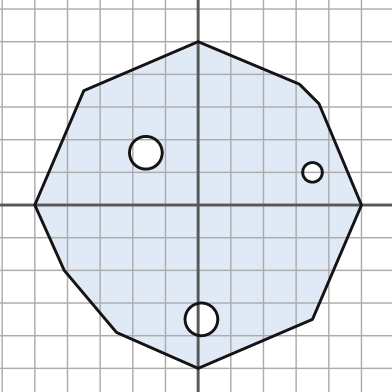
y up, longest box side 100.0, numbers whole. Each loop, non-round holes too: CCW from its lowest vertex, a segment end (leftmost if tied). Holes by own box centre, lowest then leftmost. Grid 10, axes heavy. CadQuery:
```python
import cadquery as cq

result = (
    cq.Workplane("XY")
    .moveTo(0.0, -50.0)
    .lineTo(35.0, -35.0)
    .lineTo(50.0, 0.0)
    .lineTo(37.0, 31.0)
    .lineTo(31.0, 37.0)
    .lineTo(0.0, 50.0)
    .lineTo(-35.0, 35.0)
    .lineTo(-50.0, 0.0)
    .lineTo(-41.0, -20.0)
    .lineTo(-25.0, -39.0)
    .close()
    .moveTo(1.0, -35.0)
    .circle(5.0)
    .moveTo(35.0, 10.0)
    .circle(3.0)
    .moveTo(-16.0, 16.0)
    .circle(5.0)
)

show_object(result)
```